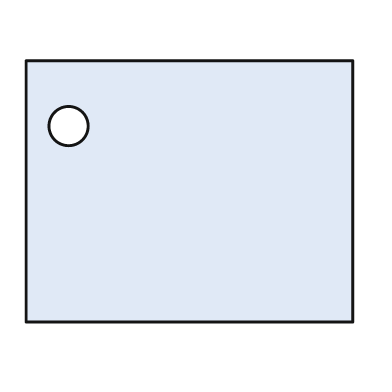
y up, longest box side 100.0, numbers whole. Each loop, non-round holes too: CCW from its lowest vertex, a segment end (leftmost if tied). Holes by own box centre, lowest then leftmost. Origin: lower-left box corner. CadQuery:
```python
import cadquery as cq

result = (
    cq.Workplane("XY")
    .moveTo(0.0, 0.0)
    .lineTo(100.0, 0.0)
    .lineTo(100.0, 80.0)
    .lineTo(0.0, 80.0)
    .close()
    .moveTo(13.0, 60.0)
    .circle(6.0)
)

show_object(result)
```